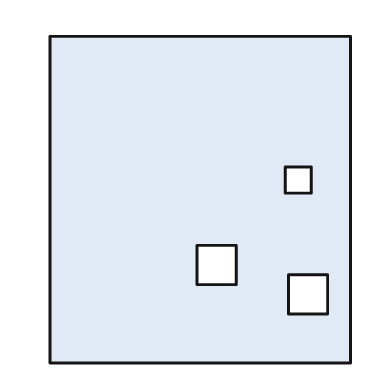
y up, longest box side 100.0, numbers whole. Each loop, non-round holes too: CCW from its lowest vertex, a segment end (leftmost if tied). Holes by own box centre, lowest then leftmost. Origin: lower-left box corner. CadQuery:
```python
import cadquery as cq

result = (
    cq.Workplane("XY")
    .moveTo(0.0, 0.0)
    .lineTo(92.0, 0.0)
    .lineTo(92.0, 100.0)
    .lineTo(0.0, 100.0)
    .close()
    .moveTo(73.0, 15.0)
    .lineTo(85.0, 15.0)
    .lineTo(85.0, 27.0)
    .lineTo(73.0, 27.0)
    .close()
    .moveTo(45.0, 24.0)
    .lineTo(57.0, 24.0)
    .lineTo(57.0, 36.0)
    .lineTo(45.0, 36.0)
    .close()
    .moveTo(72.0, 52.0)
    .lineTo(80.0, 52.0)
    .lineTo(80.0, 60.0)
    .lineTo(72.0, 60.0)
    .close()
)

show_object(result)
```